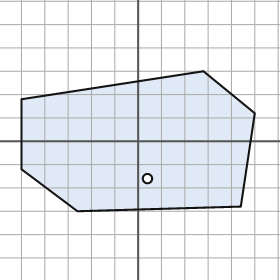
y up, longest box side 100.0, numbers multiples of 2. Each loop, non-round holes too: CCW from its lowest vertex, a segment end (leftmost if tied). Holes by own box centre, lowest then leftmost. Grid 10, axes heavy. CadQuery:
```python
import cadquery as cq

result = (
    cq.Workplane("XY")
    .moveTo(-26.0, -30.0)
    .lineTo(44.0, -28.0)
    .lineTo(50.0, 12.0)
    .lineTo(28.0, 30.0)
    .lineTo(-50.0, 18.0)
    .lineTo(-50.0, -12.0)
    .close()
    .moveTo(4.0, -16.0)
    .circle(2.0)
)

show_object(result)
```